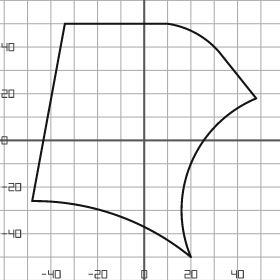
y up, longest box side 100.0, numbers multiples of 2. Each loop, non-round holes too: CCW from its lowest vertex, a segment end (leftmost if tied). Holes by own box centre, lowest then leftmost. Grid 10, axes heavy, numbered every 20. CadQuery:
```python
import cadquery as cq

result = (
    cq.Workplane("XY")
    .moveTo(20.0, -50.0)
    .threePointArc((20.0, -10.0), (48.0, 18.0))
    .lineTo(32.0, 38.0)
    .threePointArc((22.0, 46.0), (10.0, 50.0))
    .lineTo(-34.0, 50.0)
    .lineTo(-48.0, -26.0)
    .threePointArc((-12.0, -32.0), (20.0, -50.0))
    .close()
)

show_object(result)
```